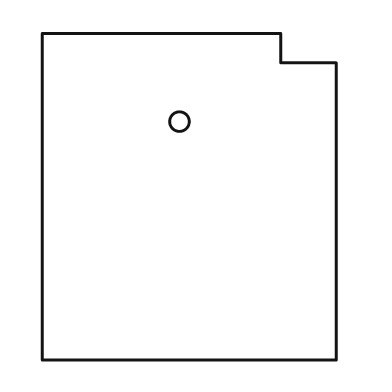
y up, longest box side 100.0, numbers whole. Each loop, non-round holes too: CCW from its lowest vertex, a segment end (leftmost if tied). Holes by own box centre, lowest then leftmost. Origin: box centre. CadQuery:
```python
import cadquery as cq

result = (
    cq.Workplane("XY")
    .moveTo(-45.0, -50.0)
    .lineTo(45.0, -50.0)
    .lineTo(45.0, 41.0)
    .lineTo(28.0, 41.0)
    .lineTo(28.0, 50.0)
    .lineTo(-45.0, 50.0)
    .close()
    .moveTo(-3.0, 23.0)
    .circle(3.0)
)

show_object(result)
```